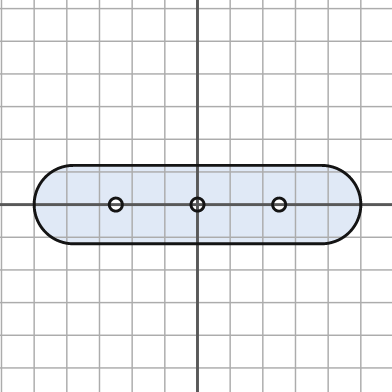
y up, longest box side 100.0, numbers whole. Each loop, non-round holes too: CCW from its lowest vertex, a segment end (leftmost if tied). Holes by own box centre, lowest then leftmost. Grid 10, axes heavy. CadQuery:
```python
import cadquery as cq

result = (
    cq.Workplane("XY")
    .moveTo(-38.0, -12.0)
    .lineTo(38.0, -12.0)
    .threePointArc((50.0, 0.0), (38.0, 12.0))
    .lineTo(-38.0, 12.0)
    .threePointArc((-50.0, 0.0), (-38.0, -12.0))
    .close()
    .moveTo(-25.0, 0.0)
    .circle(2.0)
    .moveTo(0.0, 0.0)
    .circle(2.0)
    .moveTo(25.0, 0.0)
    .circle(2.0)
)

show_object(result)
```